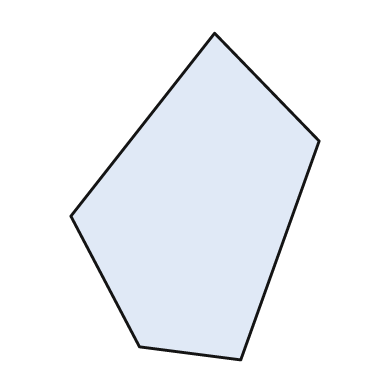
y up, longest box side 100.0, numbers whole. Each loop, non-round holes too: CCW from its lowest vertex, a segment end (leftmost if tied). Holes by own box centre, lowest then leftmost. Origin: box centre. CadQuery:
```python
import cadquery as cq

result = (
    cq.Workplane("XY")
    .moveTo(14.0, -50.0)
    .lineTo(38.0, 17.0)
    .lineTo(6.0, 50.0)
    .lineTo(-38.0, -6.0)
    .lineTo(-17.0, -46.0)
    .close()
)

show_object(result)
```